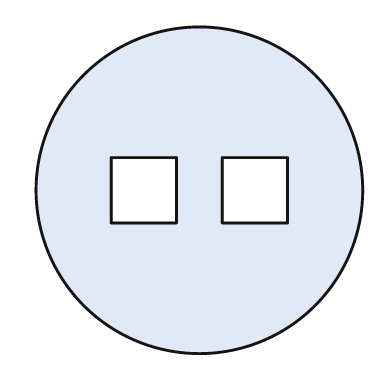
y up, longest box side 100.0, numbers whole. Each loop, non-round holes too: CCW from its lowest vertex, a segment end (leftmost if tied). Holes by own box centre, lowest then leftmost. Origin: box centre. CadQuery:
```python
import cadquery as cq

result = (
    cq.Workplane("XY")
    .moveTo(0.0, 0.0)
    .circle(50.0)
    .moveTo(-27.0, -10.0)
    .lineTo(-7.0, -10.0)
    .lineTo(-7.0, 10.0)
    .lineTo(-27.0, 10.0)
    .close()
    .moveTo(7.0, -10.0)
    .lineTo(27.0, -10.0)
    .lineTo(27.0, 10.0)
    .lineTo(7.0, 10.0)
    .close()
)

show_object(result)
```